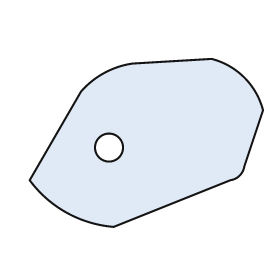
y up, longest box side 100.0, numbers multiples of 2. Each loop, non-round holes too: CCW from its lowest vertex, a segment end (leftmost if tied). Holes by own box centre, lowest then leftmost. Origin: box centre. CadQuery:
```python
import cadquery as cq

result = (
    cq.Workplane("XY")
    .moveTo(-14.0, -36.0)
    .lineTo(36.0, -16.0)
    .threePointArc((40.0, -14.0), (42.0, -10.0))
    .lineTo(50.0, 14.0)
    .threePointArc((42.0, 28.0), (28.0, 36.0))
    .lineTo(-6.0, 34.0)
    .threePointArc((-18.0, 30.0), (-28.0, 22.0))
    .lineTo(-50.0, -16.0)
    .threePointArc((-34.0, -30.0), (-14.0, -36.0))
    .close()
    .moveTo(-16.0, -2.0)
    .circle(6.0)
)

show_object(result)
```